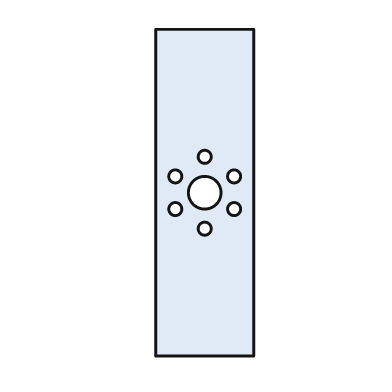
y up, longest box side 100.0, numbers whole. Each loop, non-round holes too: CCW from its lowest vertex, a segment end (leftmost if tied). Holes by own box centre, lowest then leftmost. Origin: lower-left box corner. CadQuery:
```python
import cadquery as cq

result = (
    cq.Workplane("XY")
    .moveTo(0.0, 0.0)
    .lineTo(30.0, 0.0)
    .lineTo(30.0, 100.0)
    .lineTo(0.0, 100.0)
    .close()
    .moveTo(15.0, 39.0)
    .circle(2.0)
    .moveTo(6.0, 45.0)
    .circle(2.0)
    .moveTo(24.0, 45.0)
    .circle(2.0)
    .moveTo(15.0, 50.0)
    .circle(5.0)
    .moveTo(6.0, 55.0)
    .circle(2.0)
    .moveTo(24.0, 55.0)
    .circle(2.0)
    .moveTo(15.0, 61.0)
    .circle(2.0)
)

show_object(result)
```